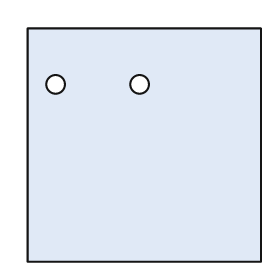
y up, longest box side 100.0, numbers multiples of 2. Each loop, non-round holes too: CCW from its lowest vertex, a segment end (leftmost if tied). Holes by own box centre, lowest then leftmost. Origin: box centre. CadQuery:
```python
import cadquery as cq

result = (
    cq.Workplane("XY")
    .moveTo(-50.0, -50.0)
    .lineTo(50.0, -50.0)
    .lineTo(50.0, 50.0)
    .lineTo(-50.0, 50.0)
    .close()
    .moveTo(-38.0, 26.0)
    .circle(4.0)
    .moveTo(-2.0, 26.0)
    .circle(4.0)
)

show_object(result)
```